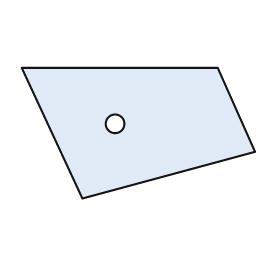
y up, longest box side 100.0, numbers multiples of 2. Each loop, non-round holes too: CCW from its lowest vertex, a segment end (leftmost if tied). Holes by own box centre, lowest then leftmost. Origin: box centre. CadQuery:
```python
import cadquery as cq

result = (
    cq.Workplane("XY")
    .moveTo(-24.0, -28.0)
    .lineTo(50.0, -8.0)
    .lineTo(34.0, 28.0)
    .lineTo(-50.0, 28.0)
    .close()
    .moveTo(-10.0, 4.0)
    .circle(4.0)
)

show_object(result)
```